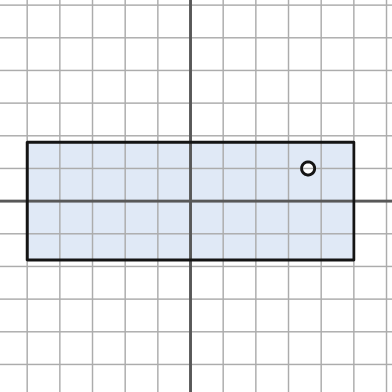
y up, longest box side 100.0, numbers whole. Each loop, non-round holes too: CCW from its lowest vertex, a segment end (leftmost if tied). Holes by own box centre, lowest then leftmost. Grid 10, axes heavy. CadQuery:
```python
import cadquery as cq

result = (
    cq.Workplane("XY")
    .moveTo(-50.0, -18.0)
    .lineTo(50.0, -18.0)
    .lineTo(50.0, 18.0)
    .lineTo(-50.0, 18.0)
    .close()
    .moveTo(36.0, 10.0)
    .circle(2.0)
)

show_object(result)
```